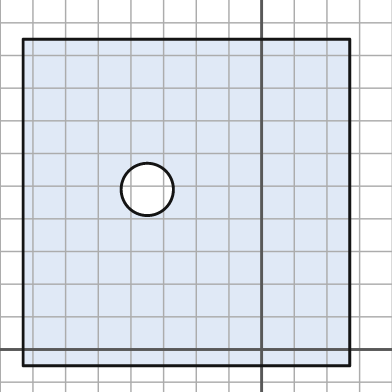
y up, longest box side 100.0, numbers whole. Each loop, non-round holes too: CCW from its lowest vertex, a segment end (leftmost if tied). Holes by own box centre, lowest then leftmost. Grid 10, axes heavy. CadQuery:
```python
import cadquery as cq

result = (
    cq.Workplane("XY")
    .moveTo(-73.0, -5.0)
    .lineTo(27.0, -5.0)
    .lineTo(27.0, 95.0)
    .lineTo(-73.0, 95.0)
    .close()
    .moveTo(-35.0, 49.0)
    .circle(8.0)
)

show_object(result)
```